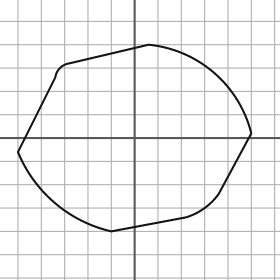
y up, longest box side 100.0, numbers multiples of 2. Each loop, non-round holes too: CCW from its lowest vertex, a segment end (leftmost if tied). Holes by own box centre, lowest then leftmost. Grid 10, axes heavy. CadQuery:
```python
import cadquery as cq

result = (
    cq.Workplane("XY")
    .moveTo(-10.0, -40.0)
    .lineTo(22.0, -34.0)
    .threePointArc((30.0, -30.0), (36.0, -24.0))
    .lineTo(50.0, 2.0)
    .threePointArc((34.0, 28.0), (6.0, 40.0))
    .lineTo(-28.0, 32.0)
    .threePointArc((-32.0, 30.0), (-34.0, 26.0))
    .lineTo(-50.0, -6.0)
    .threePointArc((-34.0, -28.0), (-10.0, -40.0))
    .close()
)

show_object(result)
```